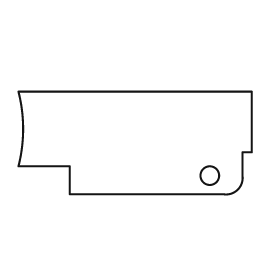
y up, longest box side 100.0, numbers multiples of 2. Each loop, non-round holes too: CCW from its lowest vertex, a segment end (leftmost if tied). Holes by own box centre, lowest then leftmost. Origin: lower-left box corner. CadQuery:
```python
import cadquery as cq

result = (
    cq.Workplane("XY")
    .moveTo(22.0, 0.0)
    .lineTo(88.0, 0.0)
    .threePointArc((94.0, 2.0), (96.0, 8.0))
    .lineTo(96.0, 18.0)
    .lineTo(100.0, 18.0)
    .lineTo(100.0, 44.0)
    .lineTo(0.0, 44.0)
    .threePointArc((2.0, 28.0), (0.0, 12.0))
    .lineTo(22.0, 12.0)
    .close()
    .moveTo(82.0, 8.0)
    .circle(4.0)
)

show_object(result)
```